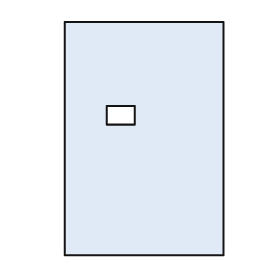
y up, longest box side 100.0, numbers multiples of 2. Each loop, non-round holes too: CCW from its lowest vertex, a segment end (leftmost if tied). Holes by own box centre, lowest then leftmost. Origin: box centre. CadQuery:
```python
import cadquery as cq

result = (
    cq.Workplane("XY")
    .moveTo(-34.0, -50.0)
    .lineTo(34.0, -50.0)
    .lineTo(34.0, 50.0)
    .lineTo(-34.0, 50.0)
    .close()
    .moveTo(-16.0, 6.0)
    .lineTo(-4.0, 6.0)
    .lineTo(-4.0, 14.0)
    .lineTo(-16.0, 14.0)
    .close()
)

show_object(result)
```